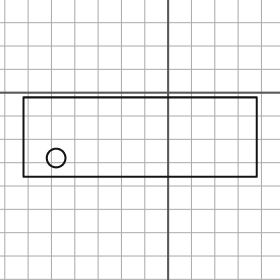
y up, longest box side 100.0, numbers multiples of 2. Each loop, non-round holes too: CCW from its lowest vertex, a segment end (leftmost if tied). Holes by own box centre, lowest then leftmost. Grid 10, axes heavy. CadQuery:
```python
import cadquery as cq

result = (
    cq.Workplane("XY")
    .moveTo(-62.0, -36.0)
    .lineTo(38.0, -36.0)
    .lineTo(38.0, -2.0)
    .lineTo(-62.0, -2.0)
    .close()
    .moveTo(-48.0, -28.0)
    .circle(4.0)
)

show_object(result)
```